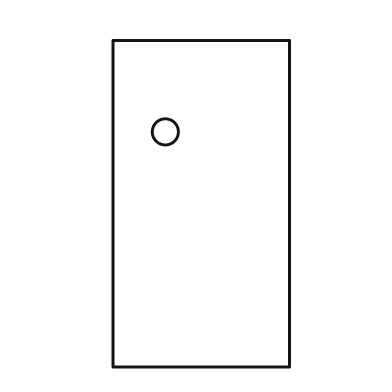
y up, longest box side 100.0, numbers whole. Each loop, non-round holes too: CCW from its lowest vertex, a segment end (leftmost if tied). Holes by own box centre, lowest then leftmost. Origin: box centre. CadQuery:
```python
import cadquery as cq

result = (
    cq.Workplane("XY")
    .moveTo(-27.0, -50.0)
    .lineTo(27.0, -50.0)
    .lineTo(27.0, 50.0)
    .lineTo(-27.0, 50.0)
    .close()
    .moveTo(-11.0, 22.0)
    .circle(4.0)
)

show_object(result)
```